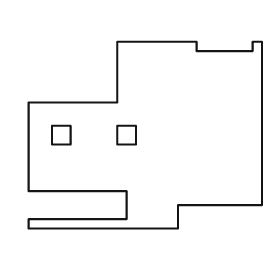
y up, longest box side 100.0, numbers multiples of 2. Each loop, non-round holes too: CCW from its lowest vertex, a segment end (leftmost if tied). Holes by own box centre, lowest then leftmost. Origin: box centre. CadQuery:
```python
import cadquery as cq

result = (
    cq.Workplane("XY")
    .moveTo(-50.0, -40.0)
    .lineTo(14.0, -40.0)
    .lineTo(14.0, -30.0)
    .lineTo(50.0, -30.0)
    .lineTo(50.0, 40.0)
    .lineTo(46.0, 40.0)
    .lineTo(46.0, 36.0)
    .lineTo(22.0, 36.0)
    .lineTo(22.0, 40.0)
    .lineTo(-12.0, 40.0)
    .lineTo(-12.0, 14.0)
    .lineTo(-50.0, 14.0)
    .lineTo(-50.0, -24.0)
    .lineTo(-8.0, -24.0)
    .lineTo(-8.0, -36.0)
    .lineTo(-50.0, -36.0)
    .close()
    .moveTo(-40.0, -4.0)
    .lineTo(-32.0, -4.0)
    .lineTo(-32.0, 4.0)
    .lineTo(-40.0, 4.0)
    .close()
    .moveTo(-12.0, -4.0)
    .lineTo(-4.0, -4.0)
    .lineTo(-4.0, 4.0)
    .lineTo(-12.0, 4.0)
    .close()
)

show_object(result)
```